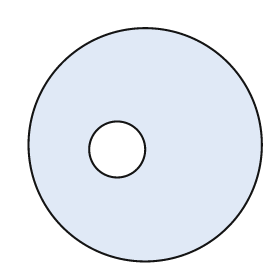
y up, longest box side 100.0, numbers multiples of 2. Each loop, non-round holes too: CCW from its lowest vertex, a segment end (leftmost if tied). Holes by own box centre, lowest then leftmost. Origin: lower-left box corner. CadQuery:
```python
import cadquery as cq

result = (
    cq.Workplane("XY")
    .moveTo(50.0, 50.0)
    .circle(50.0)
    .moveTo(38.0, 48.0)
    .circle(12.0)
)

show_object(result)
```